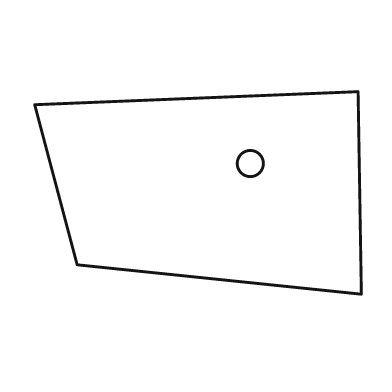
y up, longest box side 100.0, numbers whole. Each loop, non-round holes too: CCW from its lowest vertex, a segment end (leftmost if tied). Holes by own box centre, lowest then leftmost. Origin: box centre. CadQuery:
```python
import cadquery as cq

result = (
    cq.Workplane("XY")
    .moveTo(50.0, -31.0)
    .lineTo(49.0, 31.0)
    .lineTo(-50.0, 27.0)
    .lineTo(-37.0, -22.0)
    .close()
    .moveTo(16.0, 9.0)
    .circle(4.0)
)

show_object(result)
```